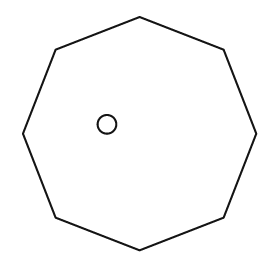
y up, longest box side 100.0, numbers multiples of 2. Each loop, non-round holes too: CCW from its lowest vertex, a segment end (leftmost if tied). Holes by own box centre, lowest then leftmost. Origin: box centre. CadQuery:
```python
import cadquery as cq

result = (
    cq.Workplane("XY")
    .moveTo(0.0, -50.0)
    .lineTo(36.0, -36.0)
    .lineTo(50.0, 0.0)
    .lineTo(36.0, 36.0)
    .lineTo(0.0, 50.0)
    .lineTo(-36.0, 36.0)
    .lineTo(-50.0, 0.0)
    .lineTo(-36.0, -36.0)
    .close()
    .moveTo(-14.0, 4.0)
    .circle(4.0)
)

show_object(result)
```